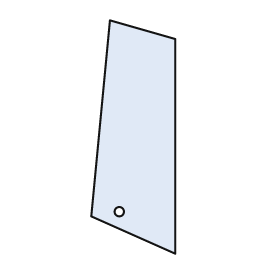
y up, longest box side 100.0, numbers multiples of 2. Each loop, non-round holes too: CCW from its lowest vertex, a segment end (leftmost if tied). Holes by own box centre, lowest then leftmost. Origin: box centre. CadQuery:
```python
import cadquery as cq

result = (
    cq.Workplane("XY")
    .moveTo(18.0, -50.0)
    .lineTo(18.0, 42.0)
    .lineTo(-10.0, 50.0)
    .lineTo(-18.0, -34.0)
    .close()
    .moveTo(-6.0, -32.0)
    .circle(2.0)
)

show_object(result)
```